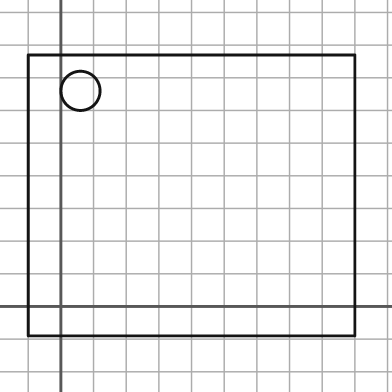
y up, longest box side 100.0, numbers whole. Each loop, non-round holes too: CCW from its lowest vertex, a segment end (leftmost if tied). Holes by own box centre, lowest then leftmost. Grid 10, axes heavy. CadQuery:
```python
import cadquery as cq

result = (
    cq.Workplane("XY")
    .moveTo(-10.0, -9.0)
    .lineTo(90.0, -9.0)
    .lineTo(90.0, 77.0)
    .lineTo(-10.0, 77.0)
    .close()
    .moveTo(6.0, 66.0)
    .circle(6.0)
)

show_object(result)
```